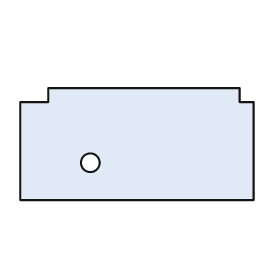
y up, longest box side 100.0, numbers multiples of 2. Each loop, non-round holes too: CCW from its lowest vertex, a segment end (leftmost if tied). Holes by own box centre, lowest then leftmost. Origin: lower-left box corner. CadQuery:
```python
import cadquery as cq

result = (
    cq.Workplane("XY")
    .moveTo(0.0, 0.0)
    .lineTo(100.0, 0.0)
    .lineTo(100.0, 42.0)
    .lineTo(94.0, 42.0)
    .lineTo(94.0, 48.0)
    .lineTo(12.0, 48.0)
    .lineTo(12.0, 42.0)
    .lineTo(0.0, 42.0)
    .close()
    .moveTo(30.0, 16.0)
    .circle(4.0)
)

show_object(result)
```